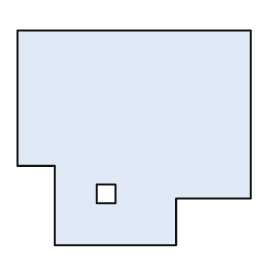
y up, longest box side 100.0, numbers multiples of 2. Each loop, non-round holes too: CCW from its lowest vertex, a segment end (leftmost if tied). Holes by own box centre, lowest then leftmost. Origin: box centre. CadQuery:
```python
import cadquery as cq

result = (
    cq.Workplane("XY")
    .moveTo(-34.0, -46.0)
    .lineTo(18.0, -46.0)
    .lineTo(18.0, -26.0)
    .lineTo(50.0, -26.0)
    .lineTo(50.0, 46.0)
    .lineTo(-50.0, 46.0)
    .lineTo(-50.0, -12.0)
    .lineTo(-34.0, -12.0)
    .close()
    .moveTo(-16.0, -28.0)
    .lineTo(-8.0, -28.0)
    .lineTo(-8.0, -20.0)
    .lineTo(-16.0, -20.0)
    .close()
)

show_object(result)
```